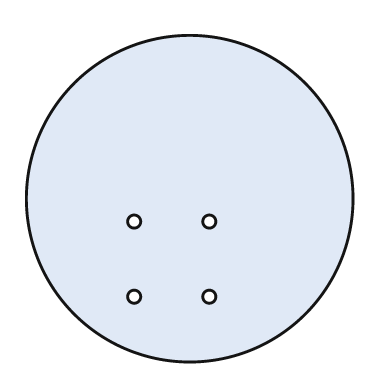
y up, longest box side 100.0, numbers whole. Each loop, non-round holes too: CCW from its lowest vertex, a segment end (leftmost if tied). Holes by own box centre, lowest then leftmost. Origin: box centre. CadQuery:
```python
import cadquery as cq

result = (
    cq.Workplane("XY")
    .moveTo(0.0, 0.0)
    .circle(50.0)
    .moveTo(-17.0, -30.0)
    .circle(2.0)
    .moveTo(6.0, -30.0)
    .circle(2.0)
    .moveTo(-17.0, -7.0)
    .circle(2.0)
    .moveTo(6.0, -7.0)
    .circle(2.0)
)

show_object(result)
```